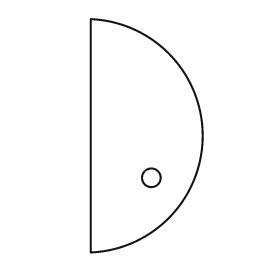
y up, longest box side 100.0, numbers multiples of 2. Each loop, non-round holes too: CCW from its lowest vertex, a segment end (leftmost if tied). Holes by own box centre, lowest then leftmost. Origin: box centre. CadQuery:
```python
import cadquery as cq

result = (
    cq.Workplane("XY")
    .moveTo(-24.0, -50.0)
    .threePointArc((24.0, 0.0), (-24.0, 50.0))
    .close()
    .moveTo(2.0, -18.0)
    .circle(4.0)
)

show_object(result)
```